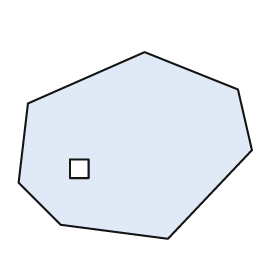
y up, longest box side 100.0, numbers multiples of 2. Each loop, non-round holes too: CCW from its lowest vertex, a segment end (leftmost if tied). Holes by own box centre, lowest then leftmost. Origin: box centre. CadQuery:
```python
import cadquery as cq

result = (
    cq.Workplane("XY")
    .moveTo(14.0, -40.0)
    .lineTo(50.0, -2.0)
    .lineTo(44.0, 24.0)
    .lineTo(4.0, 40.0)
    .lineTo(-46.0, 18.0)
    .lineTo(-50.0, -16.0)
    .lineTo(-32.0, -34.0)
    .close()
    .moveTo(-28.0, -14.0)
    .lineTo(-20.0, -14.0)
    .lineTo(-20.0, -6.0)
    .lineTo(-28.0, -6.0)
    .close()
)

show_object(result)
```